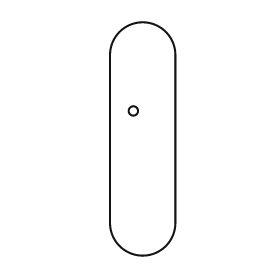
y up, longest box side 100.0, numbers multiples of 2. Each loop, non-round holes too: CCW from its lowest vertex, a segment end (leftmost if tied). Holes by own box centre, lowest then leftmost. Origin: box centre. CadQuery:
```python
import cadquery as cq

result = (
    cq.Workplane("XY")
    .moveTo(-14.0, -36.0)
    .threePointArc((0.0, -50.0), (14.0, -36.0))
    .lineTo(14.0, 36.0)
    .threePointArc((0.0, 50.0), (-14.0, 36.0))
    .close()
    .moveTo(-4.0, 12.0)
    .circle(2.0)
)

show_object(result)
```